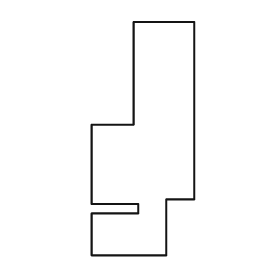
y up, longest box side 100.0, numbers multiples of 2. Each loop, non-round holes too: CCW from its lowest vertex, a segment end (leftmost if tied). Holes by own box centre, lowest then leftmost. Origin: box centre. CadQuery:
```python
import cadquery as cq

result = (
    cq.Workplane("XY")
    .moveTo(-22.0, -50.0)
    .lineTo(10.0, -50.0)
    .lineTo(10.0, -26.0)
    .lineTo(22.0, -26.0)
    .lineTo(22.0, 50.0)
    .lineTo(-4.0, 50.0)
    .lineTo(-4.0, 6.0)
    .lineTo(-22.0, 6.0)
    .lineTo(-22.0, -28.0)
    .lineTo(-2.0, -28.0)
    .lineTo(-2.0, -32.0)
    .lineTo(-22.0, -32.0)
    .close()
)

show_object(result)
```